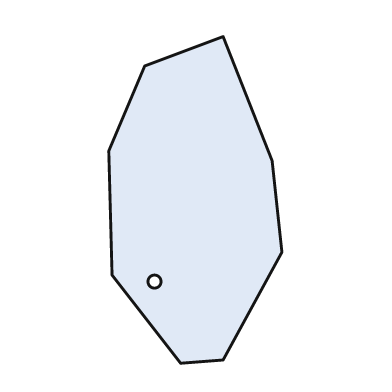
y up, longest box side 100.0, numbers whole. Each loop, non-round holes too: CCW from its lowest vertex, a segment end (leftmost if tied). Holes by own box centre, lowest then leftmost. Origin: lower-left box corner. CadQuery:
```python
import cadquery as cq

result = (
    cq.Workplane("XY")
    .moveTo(22.0, 0.0)
    .lineTo(35.0, 1.0)
    .lineTo(53.0, 34.0)
    .lineTo(50.0, 62.0)
    .lineTo(35.0, 100.0)
    .lineTo(11.0, 91.0)
    .lineTo(0.0, 65.0)
    .lineTo(1.0, 27.0)
    .close()
    .moveTo(14.0, 25.0)
    .circle(2.0)
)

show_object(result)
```